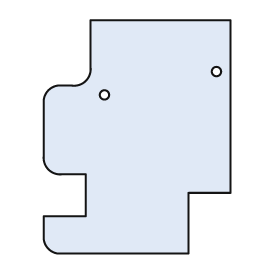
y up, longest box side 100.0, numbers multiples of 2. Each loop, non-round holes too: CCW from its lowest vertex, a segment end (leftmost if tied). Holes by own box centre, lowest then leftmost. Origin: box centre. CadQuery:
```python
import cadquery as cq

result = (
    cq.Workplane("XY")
    .moveTo(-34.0, -50.0)
    .lineTo(22.0, -50.0)
    .lineTo(22.0, -24.0)
    .lineTo(40.0, -24.0)
    .lineTo(40.0, 50.0)
    .lineTo(-20.0, 50.0)
    .lineTo(-20.0, 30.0)
    .threePointArc((-22.0, 24.0), (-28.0, 22.0))
    .lineTo(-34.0, 22.0)
    .threePointArc((-38.0, 20.0), (-40.0, 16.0))
    .lineTo(-40.0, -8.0)
    .threePointArc((-38.0, -14.0), (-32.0, -16.0))
    .lineTo(-22.0, -16.0)
    .lineTo(-22.0, -34.0)
    .lineTo(-40.0, -34.0)
    .lineTo(-40.0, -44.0)
    .threePointArc((-38.0, -48.0), (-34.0, -50.0))
    .close()
    .moveTo(-14.0, 18.0)
    .circle(2.0)
    .moveTo(34.0, 28.0)
    .circle(2.0)
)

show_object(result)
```